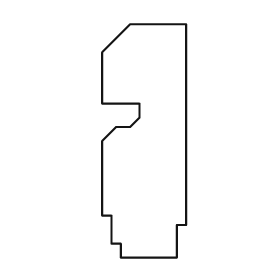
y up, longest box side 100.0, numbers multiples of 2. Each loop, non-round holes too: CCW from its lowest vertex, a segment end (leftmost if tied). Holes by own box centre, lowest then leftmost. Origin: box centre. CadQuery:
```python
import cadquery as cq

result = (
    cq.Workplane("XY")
    .moveTo(-10.0, -50.0)
    .lineTo(14.0, -50.0)
    .lineTo(14.0, -36.0)
    .lineTo(18.0, -36.0)
    .lineTo(18.0, 50.0)
    .lineTo(-6.0, 50.0)
    .lineTo(-18.0, 38.0)
    .lineTo(-18.0, 16.0)
    .lineTo(-2.0, 16.0)
    .lineTo(-2.0, 10.0)
    .lineTo(-6.0, 6.0)
    .lineTo(-12.0, 6.0)
    .lineTo(-18.0, 0.0)
    .lineTo(-18.0, -32.0)
    .lineTo(-14.0, -32.0)
    .lineTo(-14.0, -44.0)
    .lineTo(-10.0, -44.0)
    .close()
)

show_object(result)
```